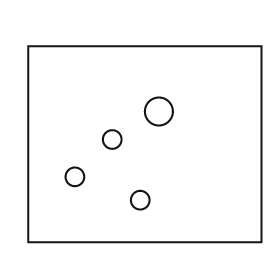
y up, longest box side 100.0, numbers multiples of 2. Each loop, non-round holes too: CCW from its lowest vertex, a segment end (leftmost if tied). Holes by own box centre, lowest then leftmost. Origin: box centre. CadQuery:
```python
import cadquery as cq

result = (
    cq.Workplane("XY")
    .moveTo(-50.0, -42.0)
    .lineTo(50.0, -42.0)
    .lineTo(50.0, 42.0)
    .lineTo(-50.0, 42.0)
    .close()
    .moveTo(-2.0, -24.0)
    .circle(4.0)
    .moveTo(-30.0, -14.0)
    .circle(4.0)
    .moveTo(-14.0, 2.0)
    .circle(4.0)
    .moveTo(6.0, 14.0)
    .circle(6.0)
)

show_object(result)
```